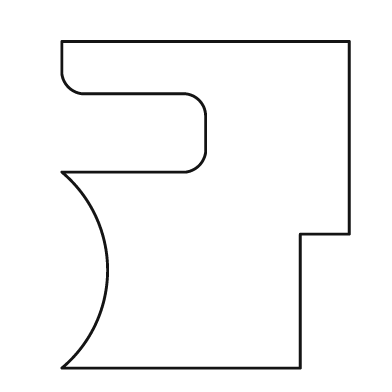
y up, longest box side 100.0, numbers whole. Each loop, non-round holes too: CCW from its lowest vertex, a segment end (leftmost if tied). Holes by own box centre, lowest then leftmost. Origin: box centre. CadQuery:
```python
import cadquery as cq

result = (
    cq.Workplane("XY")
    .moveTo(-44.0, -50.0)
    .lineTo(29.0, -50.0)
    .lineTo(29.0, -9.0)
    .lineTo(44.0, -9.0)
    .lineTo(44.0, 50.0)
    .lineTo(-44.0, 50.0)
    .lineTo(-44.0, 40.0)
    .threePointArc((-42.0, 36.0), (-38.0, 34.0))
    .lineTo(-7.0, 34.0)
    .threePointArc((-2.0, 32.0), (0.0, 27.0))
    .lineTo(0.0, 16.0)
    .threePointArc((-2.0, 12.0), (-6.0, 10.0))
    .lineTo(-44.0, 10.0)
    .threePointArc((-30.0, -20.0), (-44.0, -50.0))
    .close()
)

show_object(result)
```